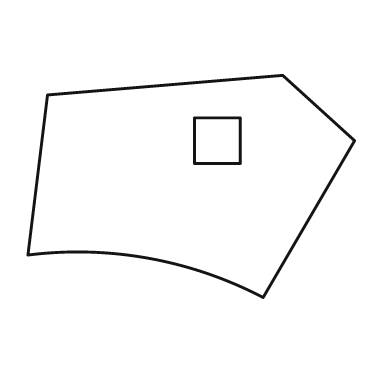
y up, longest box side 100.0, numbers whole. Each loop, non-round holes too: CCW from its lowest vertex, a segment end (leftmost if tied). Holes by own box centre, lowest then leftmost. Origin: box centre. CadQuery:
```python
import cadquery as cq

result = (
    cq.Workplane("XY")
    .moveTo(22.0, -34.0)
    .lineTo(50.0, 14.0)
    .lineTo(28.0, 34.0)
    .lineTo(-44.0, 28.0)
    .lineTo(-50.0, -21.0)
    .threePointArc((-13.0, -22.0), (22.0, -34.0))
    .close()
    .moveTo(1.0, 7.0)
    .lineTo(15.0, 7.0)
    .lineTo(15.0, 21.0)
    .lineTo(1.0, 21.0)
    .close()
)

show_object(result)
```